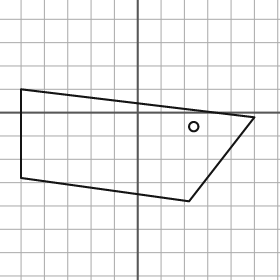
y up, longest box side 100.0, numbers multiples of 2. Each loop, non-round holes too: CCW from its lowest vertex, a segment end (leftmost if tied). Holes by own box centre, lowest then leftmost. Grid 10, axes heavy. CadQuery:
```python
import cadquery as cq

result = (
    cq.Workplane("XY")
    .moveTo(22.0, -38.0)
    .lineTo(50.0, -2.0)
    .lineTo(-50.0, 10.0)
    .lineTo(-50.0, -28.0)
    .close()
    .moveTo(24.0, -6.0)
    .circle(2.0)
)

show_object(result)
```